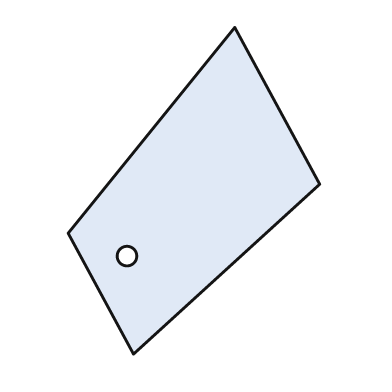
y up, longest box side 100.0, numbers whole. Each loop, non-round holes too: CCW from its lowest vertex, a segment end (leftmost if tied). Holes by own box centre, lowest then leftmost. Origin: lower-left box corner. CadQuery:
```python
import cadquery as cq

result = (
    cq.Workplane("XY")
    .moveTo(20.0, 0.0)
    .lineTo(77.0, 52.0)
    .lineTo(51.0, 100.0)
    .lineTo(0.0, 37.0)
    .close()
    .moveTo(18.0, 30.0)
    .circle(3.0)
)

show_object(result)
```